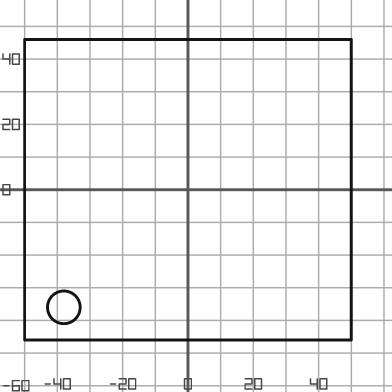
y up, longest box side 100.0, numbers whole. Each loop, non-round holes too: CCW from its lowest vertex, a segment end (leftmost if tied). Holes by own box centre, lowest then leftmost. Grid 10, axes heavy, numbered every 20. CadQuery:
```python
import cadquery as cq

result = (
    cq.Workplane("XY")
    .moveTo(-50.0, -46.0)
    .lineTo(50.0, -46.0)
    .lineTo(50.0, 46.0)
    .lineTo(-50.0, 46.0)
    .close()
    .moveTo(-38.0, -36.0)
    .circle(5.0)
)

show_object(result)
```